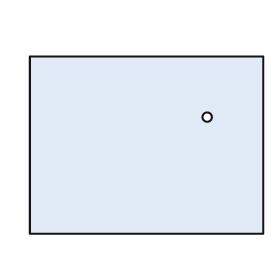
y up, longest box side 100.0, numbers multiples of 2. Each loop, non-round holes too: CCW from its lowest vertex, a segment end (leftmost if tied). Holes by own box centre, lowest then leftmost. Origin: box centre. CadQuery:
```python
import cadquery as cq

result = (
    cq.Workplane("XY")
    .moveTo(-50.0, -38.0)
    .lineTo(50.0, -38.0)
    .lineTo(50.0, 38.0)
    .lineTo(-50.0, 38.0)
    .close()
    .moveTo(26.0, 12.0)
    .circle(2.0)
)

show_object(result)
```